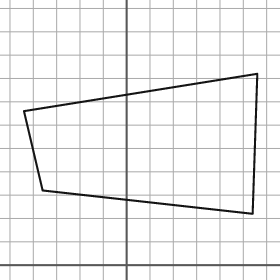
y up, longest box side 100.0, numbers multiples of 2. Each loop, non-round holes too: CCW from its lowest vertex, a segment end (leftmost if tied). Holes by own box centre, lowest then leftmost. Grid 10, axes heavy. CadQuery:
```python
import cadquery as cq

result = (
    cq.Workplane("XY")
    .moveTo(54.0, 22.0)
    .lineTo(56.0, 82.0)
    .lineTo(-44.0, 66.0)
    .lineTo(-36.0, 32.0)
    .close()
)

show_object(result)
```